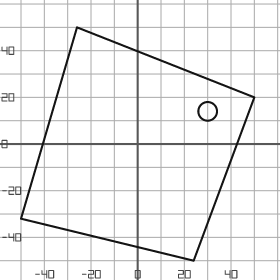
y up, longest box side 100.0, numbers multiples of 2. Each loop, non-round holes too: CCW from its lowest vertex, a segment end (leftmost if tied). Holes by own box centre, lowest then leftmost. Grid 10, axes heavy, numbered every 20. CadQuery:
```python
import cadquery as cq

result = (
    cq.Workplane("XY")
    .moveTo(24.0, -50.0)
    .lineTo(50.0, 20.0)
    .lineTo(-26.0, 50.0)
    .lineTo(-50.0, -32.0)
    .close()
    .moveTo(30.0, 14.0)
    .circle(4.0)
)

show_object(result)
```